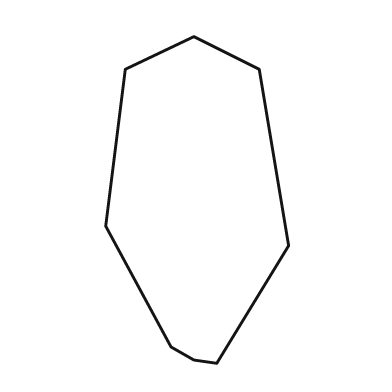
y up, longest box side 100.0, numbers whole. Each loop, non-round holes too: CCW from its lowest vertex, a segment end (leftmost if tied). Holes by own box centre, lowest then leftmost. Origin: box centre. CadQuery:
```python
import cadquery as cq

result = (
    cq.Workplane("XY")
    .moveTo(6.0, -50.0)
    .lineTo(28.0, -14.0)
    .lineTo(19.0, 40.0)
    .lineTo(-1.0, 50.0)
    .lineTo(-22.0, 40.0)
    .lineTo(-28.0, -8.0)
    .lineTo(-8.0, -45.0)
    .lineTo(-1.0, -49.0)
    .close()
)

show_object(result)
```